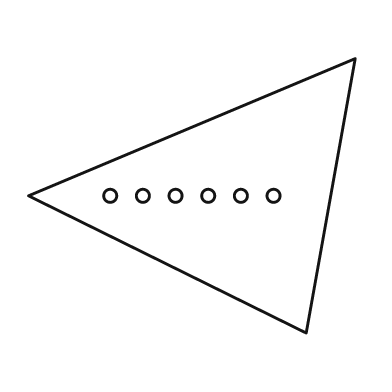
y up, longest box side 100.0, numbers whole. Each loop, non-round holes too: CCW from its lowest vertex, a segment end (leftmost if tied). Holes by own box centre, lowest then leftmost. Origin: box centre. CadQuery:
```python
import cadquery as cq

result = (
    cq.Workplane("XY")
    .moveTo(35.0, -42.0)
    .lineTo(50.0, 42.0)
    .lineTo(-50.0, 0.0)
    .close()
    .moveTo(-25.0, 0.0)
    .circle(2.0)
    .moveTo(-15.0, 0.0)
    .circle(2.0)
    .moveTo(-5.0, 0.0)
    .circle(2.0)
    .moveTo(5.0, 0.0)
    .circle(2.0)
    .moveTo(15.0, 0.0)
    .circle(2.0)
    .moveTo(25.0, 0.0)
    .circle(2.0)
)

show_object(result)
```